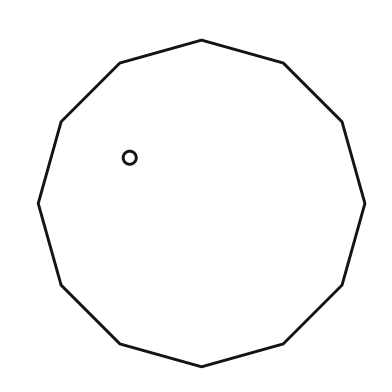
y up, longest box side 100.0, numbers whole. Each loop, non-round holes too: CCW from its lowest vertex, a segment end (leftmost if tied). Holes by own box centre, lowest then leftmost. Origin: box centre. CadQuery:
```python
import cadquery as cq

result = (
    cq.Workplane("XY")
    .moveTo(0.0, -50.0)
    .lineTo(25.0, -43.0)
    .lineTo(43.0, -25.0)
    .lineTo(50.0, 0.0)
    .lineTo(43.0, 25.0)
    .lineTo(25.0, 43.0)
    .lineTo(0.0, 50.0)
    .lineTo(-25.0, 43.0)
    .lineTo(-43.0, 25.0)
    .lineTo(-50.0, 0.0)
    .lineTo(-43.0, -25.0)
    .lineTo(-25.0, -43.0)
    .close()
    .moveTo(-22.0, 14.0)
    .circle(2.0)
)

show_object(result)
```